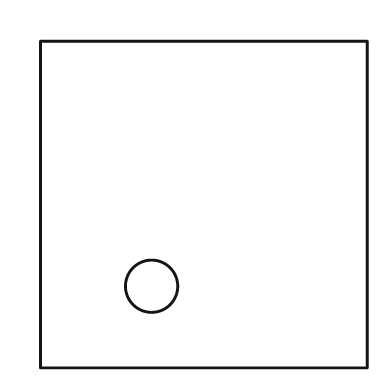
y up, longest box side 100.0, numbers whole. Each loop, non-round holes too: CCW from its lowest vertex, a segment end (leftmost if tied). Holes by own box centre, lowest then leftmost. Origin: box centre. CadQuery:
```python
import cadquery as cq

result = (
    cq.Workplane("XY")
    .moveTo(-50.0, -50.0)
    .lineTo(50.0, -50.0)
    .lineTo(50.0, 50.0)
    .lineTo(-50.0, 50.0)
    .close()
    .moveTo(-16.0, -25.0)
    .circle(8.0)
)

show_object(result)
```